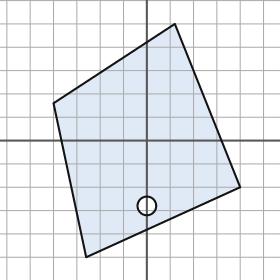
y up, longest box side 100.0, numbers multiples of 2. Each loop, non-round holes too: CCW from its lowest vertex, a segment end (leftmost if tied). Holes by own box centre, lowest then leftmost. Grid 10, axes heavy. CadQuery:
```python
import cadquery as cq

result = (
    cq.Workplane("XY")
    .moveTo(-26.0, -50.0)
    .lineTo(40.0, -20.0)
    .lineTo(12.0, 50.0)
    .lineTo(-40.0, 16.0)
    .close()
    .moveTo(0.0, -28.0)
    .circle(4.0)
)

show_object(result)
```